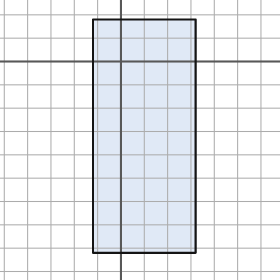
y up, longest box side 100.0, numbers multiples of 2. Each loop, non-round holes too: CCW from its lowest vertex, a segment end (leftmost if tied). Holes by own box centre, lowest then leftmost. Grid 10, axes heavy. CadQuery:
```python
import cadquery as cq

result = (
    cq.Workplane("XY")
    .moveTo(-12.0, -82.0)
    .lineTo(32.0, -82.0)
    .lineTo(32.0, 18.0)
    .lineTo(-12.0, 18.0)
    .close()
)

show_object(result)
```